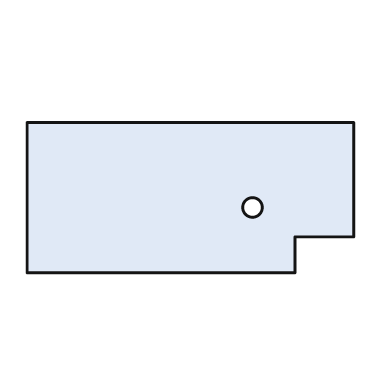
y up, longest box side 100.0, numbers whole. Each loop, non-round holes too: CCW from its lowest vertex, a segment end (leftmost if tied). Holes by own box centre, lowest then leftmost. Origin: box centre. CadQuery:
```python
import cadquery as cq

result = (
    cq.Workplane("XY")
    .moveTo(-50.0, -23.0)
    .lineTo(32.0, -23.0)
    .lineTo(32.0, -12.0)
    .lineTo(50.0, -12.0)
    .lineTo(50.0, 23.0)
    .lineTo(-50.0, 23.0)
    .close()
    .moveTo(19.0, -3.0)
    .circle(3.0)
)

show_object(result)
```